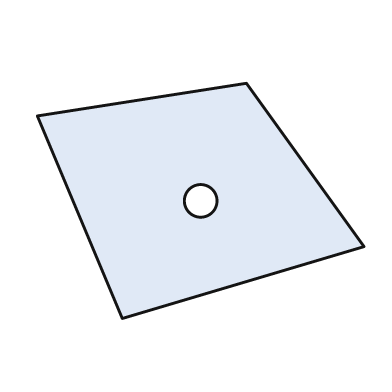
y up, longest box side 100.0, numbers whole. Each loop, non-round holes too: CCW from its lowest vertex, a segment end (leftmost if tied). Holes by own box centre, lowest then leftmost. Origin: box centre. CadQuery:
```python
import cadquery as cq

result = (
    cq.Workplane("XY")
    .moveTo(-24.0, -36.0)
    .lineTo(50.0, -14.0)
    .lineTo(14.0, 36.0)
    .lineTo(-50.0, 26.0)
    .close()
    .moveTo(0.0, 0.0)
    .circle(5.0)
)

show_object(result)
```